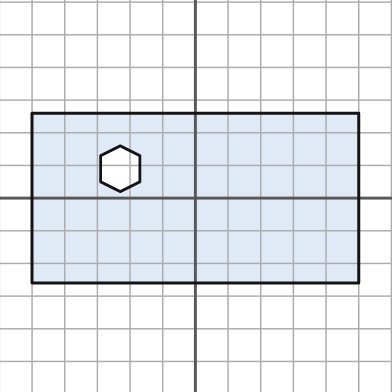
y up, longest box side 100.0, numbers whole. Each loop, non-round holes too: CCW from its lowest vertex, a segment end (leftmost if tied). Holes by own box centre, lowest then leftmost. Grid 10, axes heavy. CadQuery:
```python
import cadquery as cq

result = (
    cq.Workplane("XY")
    .moveTo(-50.0, -26.0)
    .lineTo(50.0, -26.0)
    .lineTo(50.0, 26.0)
    .lineTo(-50.0, 26.0)
    .close()
    .moveTo(-23.0, 2.0)
    .lineTo(-17.0, 5.0)
    .lineTo(-17.0, 13.0)
    .lineTo(-23.0, 16.0)
    .lineTo(-29.0, 13.0)
    .lineTo(-29.0, 5.0)
    .close()
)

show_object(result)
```